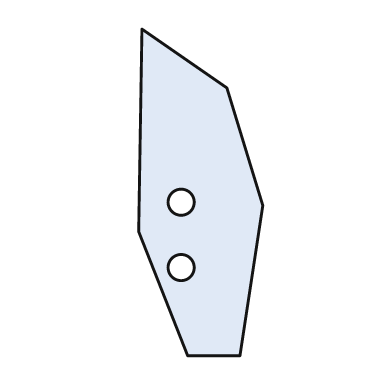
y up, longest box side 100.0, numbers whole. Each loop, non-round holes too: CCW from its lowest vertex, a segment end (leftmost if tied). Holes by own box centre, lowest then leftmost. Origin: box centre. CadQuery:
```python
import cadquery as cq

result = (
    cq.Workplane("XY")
    .moveTo(-4.0, -50.0)
    .lineTo(12.0, -50.0)
    .lineTo(19.0, -4.0)
    .lineTo(8.0, 32.0)
    .lineTo(-18.0, 50.0)
    .lineTo(-19.0, -12.0)
    .close()
    .moveTo(-6.0, -23.0)
    .circle(4.0)
    .moveTo(-6.0, -3.0)
    .circle(4.0)
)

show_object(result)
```